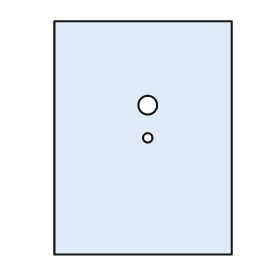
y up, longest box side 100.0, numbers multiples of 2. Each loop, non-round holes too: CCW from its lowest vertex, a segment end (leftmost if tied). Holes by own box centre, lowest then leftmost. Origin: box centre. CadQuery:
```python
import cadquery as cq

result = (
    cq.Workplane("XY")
    .moveTo(-38.0, -50.0)
    .lineTo(38.0, -50.0)
    .lineTo(38.0, 50.0)
    .lineTo(-38.0, 50.0)
    .close()
    .moveTo(2.0, 0.0)
    .circle(2.0)
    .moveTo(2.0, 14.0)
    .circle(4.0)
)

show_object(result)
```